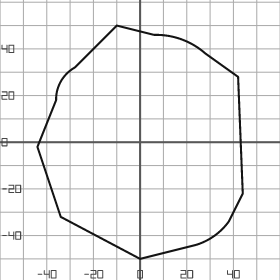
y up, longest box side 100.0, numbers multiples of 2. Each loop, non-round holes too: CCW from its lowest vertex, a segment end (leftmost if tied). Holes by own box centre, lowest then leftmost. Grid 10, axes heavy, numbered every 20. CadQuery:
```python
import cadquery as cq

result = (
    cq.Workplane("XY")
    .moveTo(0.0, -50.0)
    .lineTo(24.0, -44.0)
    .threePointArc((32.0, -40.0), (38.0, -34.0))
    .lineTo(44.0, -22.0)
    .lineTo(42.0, 28.0)
    .lineTo(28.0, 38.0)
    .threePointArc((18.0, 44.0), (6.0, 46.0))
    .lineTo(-10.0, 50.0)
    .lineTo(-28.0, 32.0)
    .threePointArc((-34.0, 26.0), (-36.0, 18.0))
    .lineTo(-44.0, -2.0)
    .lineTo(-34.0, -32.0)
    .close()
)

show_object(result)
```